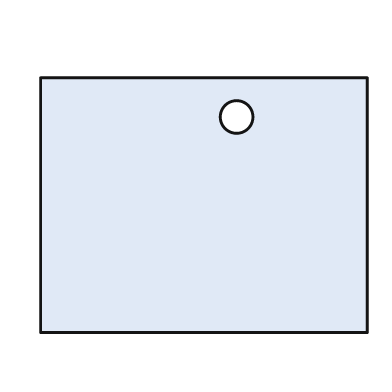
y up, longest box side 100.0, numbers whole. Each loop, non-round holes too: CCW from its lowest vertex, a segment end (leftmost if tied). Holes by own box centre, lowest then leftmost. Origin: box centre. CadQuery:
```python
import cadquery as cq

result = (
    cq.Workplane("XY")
    .moveTo(-50.0, -39.0)
    .lineTo(50.0, -39.0)
    .lineTo(50.0, 39.0)
    .lineTo(-50.0, 39.0)
    .close()
    .moveTo(10.0, 27.0)
    .circle(5.0)
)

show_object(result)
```